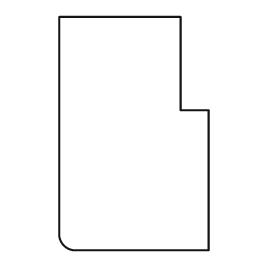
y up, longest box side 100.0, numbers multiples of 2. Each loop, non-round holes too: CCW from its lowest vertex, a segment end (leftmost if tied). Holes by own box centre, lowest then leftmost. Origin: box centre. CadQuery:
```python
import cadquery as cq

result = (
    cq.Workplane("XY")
    .moveTo(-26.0, -50.0)
    .lineTo(32.0, -50.0)
    .lineTo(32.0, 10.0)
    .lineTo(20.0, 10.0)
    .lineTo(20.0, 50.0)
    .lineTo(-32.0, 50.0)
    .lineTo(-32.0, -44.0)
    .threePointArc((-30.0, -48.0), (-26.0, -50.0))
    .close()
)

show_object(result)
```